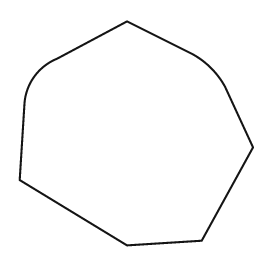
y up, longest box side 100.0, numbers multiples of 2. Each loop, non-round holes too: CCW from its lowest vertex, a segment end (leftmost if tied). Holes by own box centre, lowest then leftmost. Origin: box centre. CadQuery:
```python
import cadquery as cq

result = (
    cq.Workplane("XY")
    .moveTo(-4.0, -48.0)
    .lineTo(28.0, -46.0)
    .lineTo(50.0, -6.0)
    .lineTo(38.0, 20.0)
    .threePointArc((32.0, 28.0), (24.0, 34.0))
    .lineTo(-4.0, 48.0)
    .lineTo(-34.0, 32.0)
    .threePointArc((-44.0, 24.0), (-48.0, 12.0))
    .lineTo(-50.0, -20.0)
    .close()
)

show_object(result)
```